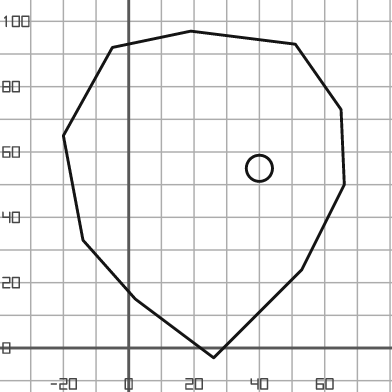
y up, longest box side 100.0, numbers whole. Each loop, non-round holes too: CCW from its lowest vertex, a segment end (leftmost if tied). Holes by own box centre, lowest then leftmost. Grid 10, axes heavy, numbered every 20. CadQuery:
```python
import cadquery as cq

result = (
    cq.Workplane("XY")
    .moveTo(26.0, -3.0)
    .lineTo(53.0, 24.0)
    .lineTo(66.0, 50.0)
    .lineTo(65.0, 73.0)
    .lineTo(51.0, 93.0)
    .lineTo(19.0, 97.0)
    .lineTo(-5.0, 92.0)
    .lineTo(-20.0, 65.0)
    .lineTo(-14.0, 33.0)
    .lineTo(2.0, 15.0)
    .close()
    .moveTo(40.0, 55.0)
    .circle(4.0)
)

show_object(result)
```